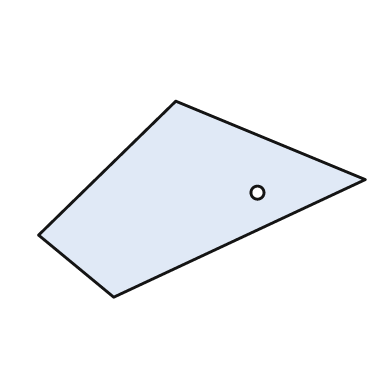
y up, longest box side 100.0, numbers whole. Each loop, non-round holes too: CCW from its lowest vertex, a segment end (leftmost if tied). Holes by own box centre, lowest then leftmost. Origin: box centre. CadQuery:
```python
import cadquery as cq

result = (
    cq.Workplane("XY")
    .moveTo(-27.0, -30.0)
    .lineTo(50.0, 6.0)
    .lineTo(-8.0, 30.0)
    .lineTo(-50.0, -11.0)
    .close()
    .moveTo(17.0, 2.0)
    .circle(2.0)
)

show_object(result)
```